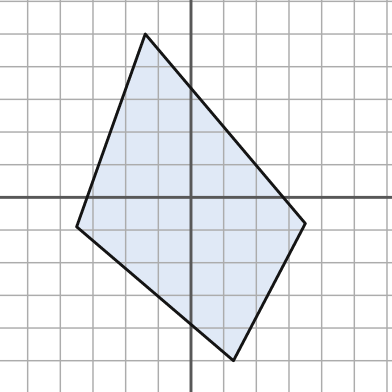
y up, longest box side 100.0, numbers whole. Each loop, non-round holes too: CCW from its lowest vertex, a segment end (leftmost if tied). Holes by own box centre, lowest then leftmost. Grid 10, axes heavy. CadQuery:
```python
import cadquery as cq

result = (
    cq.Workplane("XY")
    .moveTo(13.0, -50.0)
    .lineTo(35.0, -8.0)
    .lineTo(-14.0, 50.0)
    .lineTo(-35.0, -9.0)
    .close()
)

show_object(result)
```